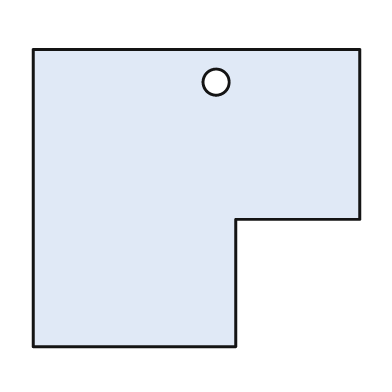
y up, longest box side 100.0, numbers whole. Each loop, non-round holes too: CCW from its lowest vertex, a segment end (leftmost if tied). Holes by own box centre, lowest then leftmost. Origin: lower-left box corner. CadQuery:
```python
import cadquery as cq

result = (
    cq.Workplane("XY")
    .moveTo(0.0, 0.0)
    .lineTo(62.0, 0.0)
    .lineTo(62.0, 39.0)
    .lineTo(100.0, 39.0)
    .lineTo(100.0, 91.0)
    .lineTo(0.0, 91.0)
    .close()
    .moveTo(56.0, 81.0)
    .circle(4.0)
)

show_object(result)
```